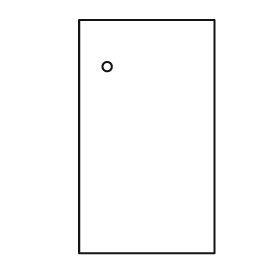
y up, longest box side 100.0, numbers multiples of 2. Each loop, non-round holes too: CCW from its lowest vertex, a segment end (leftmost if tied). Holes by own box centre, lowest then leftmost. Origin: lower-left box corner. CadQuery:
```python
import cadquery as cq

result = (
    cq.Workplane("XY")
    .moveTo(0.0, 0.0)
    .lineTo(58.0, 0.0)
    .lineTo(58.0, 100.0)
    .lineTo(0.0, 100.0)
    .close()
    .moveTo(12.0, 80.0)
    .circle(2.0)
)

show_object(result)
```